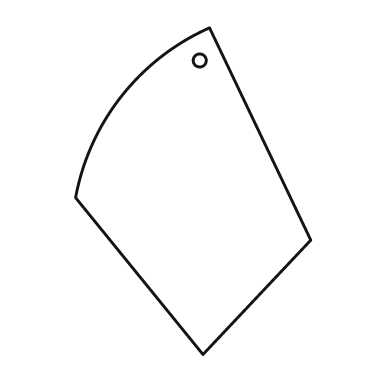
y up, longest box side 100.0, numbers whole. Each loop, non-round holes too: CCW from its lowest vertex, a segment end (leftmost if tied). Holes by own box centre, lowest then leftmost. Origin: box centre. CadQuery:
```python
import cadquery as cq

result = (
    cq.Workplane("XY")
    .moveTo(3.0, -50.0)
    .lineTo(36.0, -15.0)
    .lineTo(5.0, 50.0)
    .threePointArc((-22.0, 29.0), (-36.0, -2.0))
    .close()
    .moveTo(2.0, 40.0)
    .circle(2.0)
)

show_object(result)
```